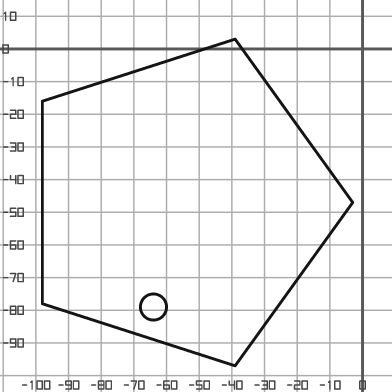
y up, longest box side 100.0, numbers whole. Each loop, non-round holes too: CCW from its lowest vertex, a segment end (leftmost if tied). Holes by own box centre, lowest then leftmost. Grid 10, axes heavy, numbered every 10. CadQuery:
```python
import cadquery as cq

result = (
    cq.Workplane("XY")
    .moveTo(-39.0, -97.0)
    .lineTo(-3.0, -47.0)
    .lineTo(-39.0, 3.0)
    .lineTo(-98.0, -16.0)
    .lineTo(-98.0, -78.0)
    .close()
    .moveTo(-64.0, -79.0)
    .circle(4.0)
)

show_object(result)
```